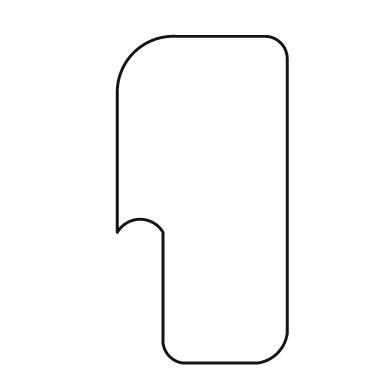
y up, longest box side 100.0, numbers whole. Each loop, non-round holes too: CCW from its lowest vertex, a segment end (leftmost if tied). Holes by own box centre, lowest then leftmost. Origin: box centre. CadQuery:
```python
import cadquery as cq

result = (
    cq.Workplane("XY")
    .moveTo(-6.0, -50.0)
    .lineTo(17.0, -50.0)
    .threePointArc((23.0, -47.0), (26.0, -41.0))
    .lineTo(26.0, 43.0)
    .threePointArc((24.0, 48.0), (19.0, 50.0))
    .lineTo(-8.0, 50.0)
    .threePointArc((-21.0, 45.0), (-26.0, 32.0))
    .lineTo(-26.0, -10.0)
    .threePointArc((-19.0, -6.0), (-12.0, -10.0))
    .lineTo(-12.0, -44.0)
    .threePointArc((-10.0, -48.0), (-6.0, -50.0))
    .close()
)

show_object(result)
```